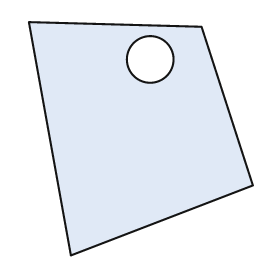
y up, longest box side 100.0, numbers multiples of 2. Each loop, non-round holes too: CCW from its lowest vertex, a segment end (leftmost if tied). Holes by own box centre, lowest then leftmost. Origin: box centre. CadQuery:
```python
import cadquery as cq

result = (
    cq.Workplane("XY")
    .moveTo(-30.0, -50.0)
    .lineTo(48.0, -20.0)
    .lineTo(26.0, 48.0)
    .lineTo(-48.0, 50.0)
    .close()
    .moveTo(4.0, 34.0)
    .circle(10.0)
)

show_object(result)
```